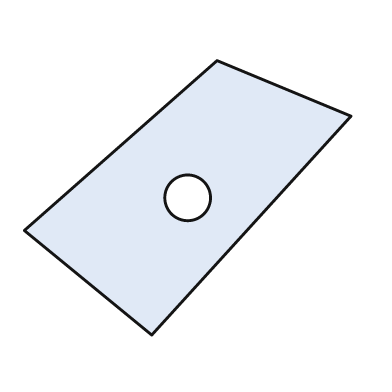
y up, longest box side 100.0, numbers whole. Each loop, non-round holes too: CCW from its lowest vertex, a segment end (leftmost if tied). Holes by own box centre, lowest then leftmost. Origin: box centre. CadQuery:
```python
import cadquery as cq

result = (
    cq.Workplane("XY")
    .moveTo(-11.0, -42.0)
    .lineTo(50.0, 25.0)
    .lineTo(9.0, 42.0)
    .lineTo(-50.0, -10.0)
    .close()
    .moveTo(0.0, 0.0)
    .circle(7.0)
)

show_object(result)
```